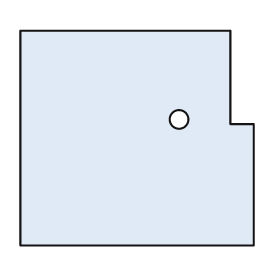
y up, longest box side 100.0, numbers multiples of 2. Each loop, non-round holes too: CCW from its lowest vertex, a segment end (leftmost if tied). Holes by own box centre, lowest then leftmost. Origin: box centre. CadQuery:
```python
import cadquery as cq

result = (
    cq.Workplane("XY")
    .moveTo(-50.0, -46.0)
    .lineTo(50.0, -46.0)
    .lineTo(50.0, 6.0)
    .lineTo(40.0, 6.0)
    .lineTo(40.0, 46.0)
    .lineTo(-50.0, 46.0)
    .close()
    .moveTo(18.0, 8.0)
    .circle(4.0)
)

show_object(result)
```